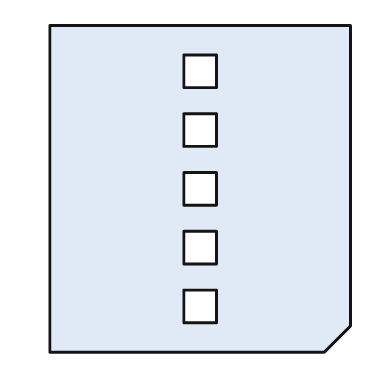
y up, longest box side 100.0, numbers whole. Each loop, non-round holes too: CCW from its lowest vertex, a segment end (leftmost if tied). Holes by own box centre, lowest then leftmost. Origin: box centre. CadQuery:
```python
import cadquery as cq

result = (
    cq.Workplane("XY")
    .moveTo(-46.0, -50.0)
    .lineTo(38.0, -50.0)
    .lineTo(46.0, -42.0)
    .lineTo(46.0, 50.0)
    .lineTo(-46.0, 50.0)
    .close()
    .moveTo(-5.0, -41.0)
    .lineTo(5.0, -41.0)
    .lineTo(5.0, -31.0)
    .lineTo(-5.0, -31.0)
    .close()
    .moveTo(-5.0, -23.0)
    .lineTo(5.0, -23.0)
    .lineTo(5.0, -13.0)
    .lineTo(-5.0, -13.0)
    .close()
    .moveTo(-5.0, -5.0)
    .lineTo(5.0, -5.0)
    .lineTo(5.0, 5.0)
    .lineTo(-5.0, 5.0)
    .close()
    .moveTo(-5.0, 13.0)
    .lineTo(5.0, 13.0)
    .lineTo(5.0, 23.0)
    .lineTo(-5.0, 23.0)
    .close()
    .moveTo(-5.0, 31.0)
    .lineTo(5.0, 31.0)
    .lineTo(5.0, 41.0)
    .lineTo(-5.0, 41.0)
    .close()
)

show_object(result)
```